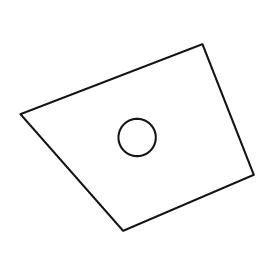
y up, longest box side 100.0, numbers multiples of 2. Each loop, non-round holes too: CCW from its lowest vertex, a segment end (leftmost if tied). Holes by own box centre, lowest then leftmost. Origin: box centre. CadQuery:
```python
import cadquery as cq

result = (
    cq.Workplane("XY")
    .moveTo(-6.0, -40.0)
    .lineTo(50.0, -16.0)
    .lineTo(28.0, 40.0)
    .lineTo(-50.0, 10.0)
    .close()
    .moveTo(0.0, 0.0)
    .circle(8.0)
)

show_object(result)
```